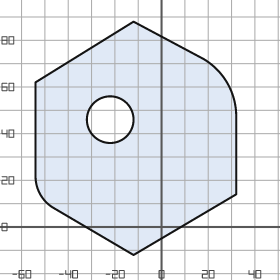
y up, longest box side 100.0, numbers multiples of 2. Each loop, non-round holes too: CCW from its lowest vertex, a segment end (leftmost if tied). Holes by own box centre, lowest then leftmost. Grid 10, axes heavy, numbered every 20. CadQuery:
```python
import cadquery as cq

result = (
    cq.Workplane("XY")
    .moveTo(-12.0, -12.0)
    .lineTo(32.0, 14.0)
    .lineTo(32.0, 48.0)
    .threePointArc((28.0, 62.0), (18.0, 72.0))
    .lineTo(-12.0, 88.0)
    .lineTo(-54.0, 62.0)
    .lineTo(-54.0, 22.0)
    .threePointArc((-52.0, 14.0), (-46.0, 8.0))
    .close()
    .moveTo(-22.0, 46.0)
    .circle(10.0)
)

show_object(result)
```